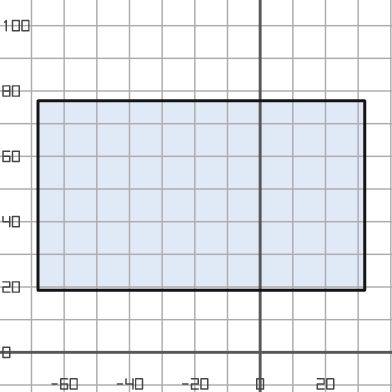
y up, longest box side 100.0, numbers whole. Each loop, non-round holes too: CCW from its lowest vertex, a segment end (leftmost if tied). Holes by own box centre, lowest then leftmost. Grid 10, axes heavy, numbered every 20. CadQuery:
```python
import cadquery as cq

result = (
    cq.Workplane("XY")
    .moveTo(-68.0, 19.0)
    .lineTo(32.0, 19.0)
    .lineTo(32.0, 77.0)
    .lineTo(-68.0, 77.0)
    .close()
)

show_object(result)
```